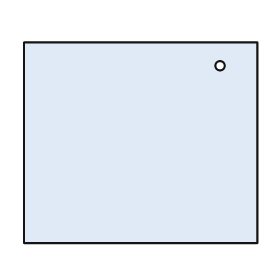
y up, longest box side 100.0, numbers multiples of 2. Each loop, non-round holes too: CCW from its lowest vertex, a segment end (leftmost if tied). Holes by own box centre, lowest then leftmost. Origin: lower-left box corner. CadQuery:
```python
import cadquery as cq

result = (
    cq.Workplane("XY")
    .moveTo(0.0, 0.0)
    .lineTo(100.0, 0.0)
    .lineTo(100.0, 86.0)
    .lineTo(0.0, 86.0)
    .close()
    .moveTo(84.0, 76.0)
    .circle(2.0)
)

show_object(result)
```